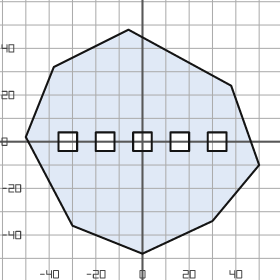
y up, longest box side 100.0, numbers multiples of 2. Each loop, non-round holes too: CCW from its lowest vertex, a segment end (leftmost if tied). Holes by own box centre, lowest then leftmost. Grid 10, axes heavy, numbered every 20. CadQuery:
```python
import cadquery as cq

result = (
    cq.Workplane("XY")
    .moveTo(0.0, -48.0)
    .lineTo(30.0, -34.0)
    .lineTo(50.0, -10.0)
    .lineTo(38.0, 24.0)
    .lineTo(-6.0, 48.0)
    .lineTo(-38.0, 32.0)
    .lineTo(-50.0, 2.0)
    .lineTo(-30.0, -36.0)
    .close()
    .moveTo(-36.0, -4.0)
    .lineTo(-28.0, -4.0)
    .lineTo(-28.0, 4.0)
    .lineTo(-36.0, 4.0)
    .close()
    .moveTo(-20.0, -4.0)
    .lineTo(-12.0, -4.0)
    .lineTo(-12.0, 4.0)
    .lineTo(-20.0, 4.0)
    .close()
    .moveTo(-4.0, -4.0)
    .lineTo(4.0, -4.0)
    .lineTo(4.0, 4.0)
    .lineTo(-4.0, 4.0)
    .close()
    .moveTo(12.0, -4.0)
    .lineTo(20.0, -4.0)
    .lineTo(20.0, 4.0)
    .lineTo(12.0, 4.0)
    .close()
    .moveTo(28.0, -4.0)
    .lineTo(36.0, -4.0)
    .lineTo(36.0, 4.0)
    .lineTo(28.0, 4.0)
    .close()
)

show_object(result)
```